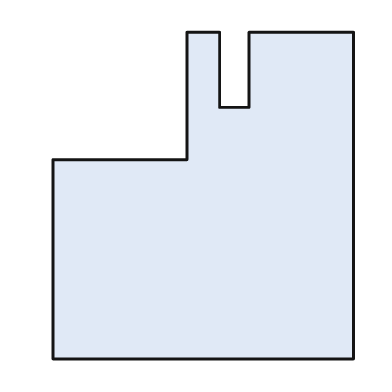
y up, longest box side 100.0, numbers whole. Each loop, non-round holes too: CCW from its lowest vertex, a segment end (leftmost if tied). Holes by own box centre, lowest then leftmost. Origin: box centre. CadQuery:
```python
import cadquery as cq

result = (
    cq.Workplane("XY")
    .moveTo(-46.0, -50.0)
    .lineTo(46.0, -50.0)
    .lineTo(46.0, 50.0)
    .lineTo(14.0, 50.0)
    .lineTo(14.0, 27.0)
    .lineTo(5.0, 27.0)
    .lineTo(5.0, 50.0)
    .lineTo(-5.0, 50.0)
    .lineTo(-5.0, 11.0)
    .lineTo(-46.0, 11.0)
    .close()
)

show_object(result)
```